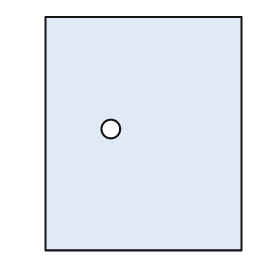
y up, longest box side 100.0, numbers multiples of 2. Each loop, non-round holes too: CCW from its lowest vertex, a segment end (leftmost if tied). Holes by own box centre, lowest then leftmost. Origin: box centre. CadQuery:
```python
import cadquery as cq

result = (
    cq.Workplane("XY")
    .moveTo(-42.0, -50.0)
    .lineTo(42.0, -50.0)
    .lineTo(42.0, 50.0)
    .lineTo(-42.0, 50.0)
    .close()
    .moveTo(-14.0, 2.0)
    .circle(4.0)
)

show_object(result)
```